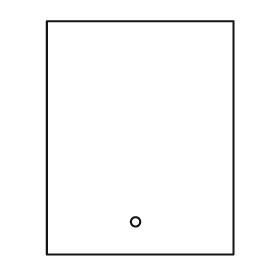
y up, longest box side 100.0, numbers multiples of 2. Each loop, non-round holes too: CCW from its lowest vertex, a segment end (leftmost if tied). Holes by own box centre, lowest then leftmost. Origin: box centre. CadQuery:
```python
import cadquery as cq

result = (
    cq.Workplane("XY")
    .moveTo(-40.0, -50.0)
    .lineTo(40.0, -50.0)
    .lineTo(40.0, 50.0)
    .lineTo(-40.0, 50.0)
    .close()
    .moveTo(-2.0, -36.0)
    .circle(2.0)
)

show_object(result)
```